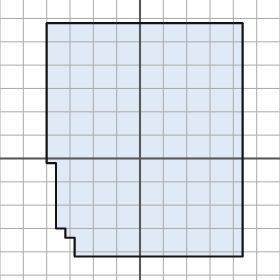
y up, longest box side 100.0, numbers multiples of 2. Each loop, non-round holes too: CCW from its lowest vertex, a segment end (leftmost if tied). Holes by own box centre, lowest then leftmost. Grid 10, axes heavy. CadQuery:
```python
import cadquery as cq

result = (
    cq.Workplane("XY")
    .moveTo(-28.0, -42.0)
    .lineTo(44.0, -42.0)
    .lineTo(44.0, 58.0)
    .lineTo(-40.0, 58.0)
    .lineTo(-40.0, -2.0)
    .lineTo(-36.0, -2.0)
    .lineTo(-36.0, -30.0)
    .lineTo(-32.0, -30.0)
    .lineTo(-32.0, -34.0)
    .lineTo(-28.0, -34.0)
    .close()
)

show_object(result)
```